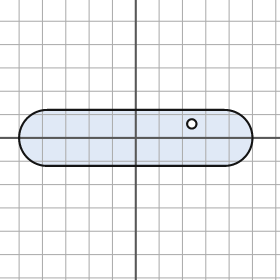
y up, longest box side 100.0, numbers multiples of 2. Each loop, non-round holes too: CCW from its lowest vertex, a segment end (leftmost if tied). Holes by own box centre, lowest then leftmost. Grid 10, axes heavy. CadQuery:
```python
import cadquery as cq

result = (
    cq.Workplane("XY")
    .moveTo(-38.0, -12.0)
    .lineTo(38.0, -12.0)
    .threePointArc((50.0, 0.0), (38.0, 12.0))
    .lineTo(-38.0, 12.0)
    .threePointArc((-50.0, 0.0), (-38.0, -12.0))
    .close()
    .moveTo(24.0, 6.0)
    .circle(2.0)
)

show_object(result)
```